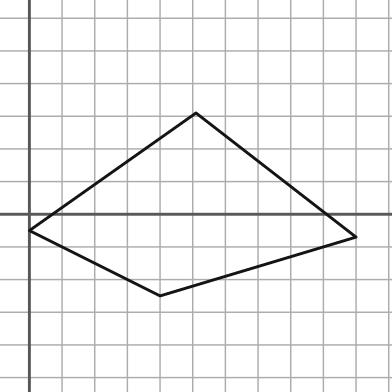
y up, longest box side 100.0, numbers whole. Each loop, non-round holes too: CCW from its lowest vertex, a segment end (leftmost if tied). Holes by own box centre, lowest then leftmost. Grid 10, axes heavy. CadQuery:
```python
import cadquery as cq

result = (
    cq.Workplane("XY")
    .moveTo(40.0, -25.0)
    .lineTo(100.0, -7.0)
    .lineTo(51.0, 31.0)
    .lineTo(0.0, -5.0)
    .close()
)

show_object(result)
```